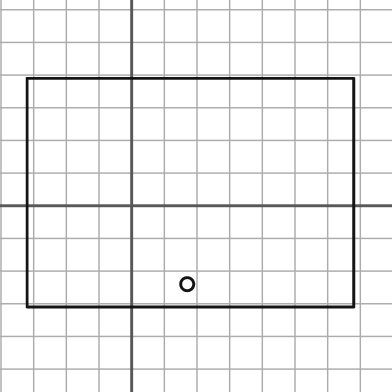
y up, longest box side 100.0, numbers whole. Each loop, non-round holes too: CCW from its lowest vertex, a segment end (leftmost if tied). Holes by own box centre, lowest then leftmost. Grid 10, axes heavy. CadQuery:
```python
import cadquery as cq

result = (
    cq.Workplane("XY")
    .moveTo(-32.0, -31.0)
    .lineTo(68.0, -31.0)
    .lineTo(68.0, 39.0)
    .lineTo(-32.0, 39.0)
    .close()
    .moveTo(17.0, -24.0)
    .circle(2.0)
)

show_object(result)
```